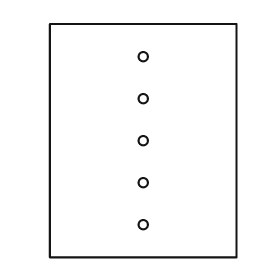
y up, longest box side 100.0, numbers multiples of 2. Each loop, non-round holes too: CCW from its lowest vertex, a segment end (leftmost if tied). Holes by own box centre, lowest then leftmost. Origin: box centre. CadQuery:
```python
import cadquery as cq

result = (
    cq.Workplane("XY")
    .moveTo(-40.0, -50.0)
    .lineTo(40.0, -50.0)
    .lineTo(40.0, 50.0)
    .lineTo(-40.0, 50.0)
    .close()
    .moveTo(0.0, -36.0)
    .circle(2.0)
    .moveTo(0.0, -18.0)
    .circle(2.0)
    .moveTo(0.0, 0.0)
    .circle(2.0)
    .moveTo(0.0, 18.0)
    .circle(2.0)
    .moveTo(0.0, 36.0)
    .circle(2.0)
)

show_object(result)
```